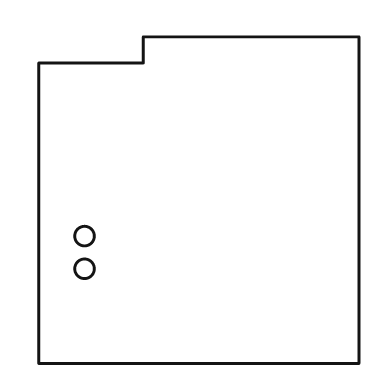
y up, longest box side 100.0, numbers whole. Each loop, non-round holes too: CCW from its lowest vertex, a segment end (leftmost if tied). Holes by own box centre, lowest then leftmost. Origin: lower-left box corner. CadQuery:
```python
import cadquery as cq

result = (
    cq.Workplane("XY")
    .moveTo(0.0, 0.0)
    .lineTo(98.0, 0.0)
    .lineTo(98.0, 100.0)
    .lineTo(32.0, 100.0)
    .lineTo(32.0, 92.0)
    .lineTo(0.0, 92.0)
    .close()
    .moveTo(14.0, 29.0)
    .circle(3.0)
    .moveTo(14.0, 39.0)
    .circle(3.0)
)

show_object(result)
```